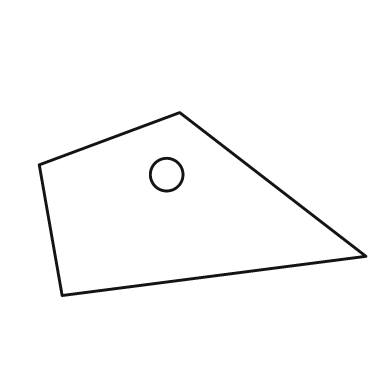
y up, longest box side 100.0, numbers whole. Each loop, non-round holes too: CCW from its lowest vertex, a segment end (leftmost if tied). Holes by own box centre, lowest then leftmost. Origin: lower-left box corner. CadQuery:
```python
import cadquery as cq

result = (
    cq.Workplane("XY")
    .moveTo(7.0, 0.0)
    .lineTo(100.0, 12.0)
    .lineTo(43.0, 56.0)
    .lineTo(0.0, 40.0)
    .close()
    .moveTo(39.0, 37.0)
    .circle(5.0)
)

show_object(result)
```